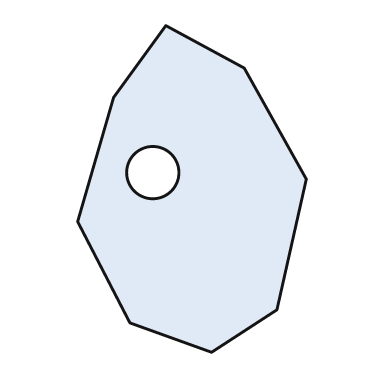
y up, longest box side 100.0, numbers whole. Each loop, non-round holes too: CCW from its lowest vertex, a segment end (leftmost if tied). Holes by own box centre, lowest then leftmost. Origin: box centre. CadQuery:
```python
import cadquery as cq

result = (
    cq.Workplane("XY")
    .moveTo(6.0, -50.0)
    .lineTo(26.0, -37.0)
    .lineTo(35.0, 3.0)
    .lineTo(16.0, 37.0)
    .lineTo(-8.0, 50.0)
    .lineTo(-24.0, 28.0)
    .lineTo(-35.0, -10.0)
    .lineTo(-19.0, -41.0)
    .close()
    .moveTo(-12.0, 5.0)
    .circle(8.0)
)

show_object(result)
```